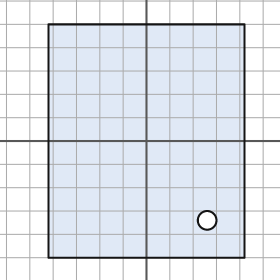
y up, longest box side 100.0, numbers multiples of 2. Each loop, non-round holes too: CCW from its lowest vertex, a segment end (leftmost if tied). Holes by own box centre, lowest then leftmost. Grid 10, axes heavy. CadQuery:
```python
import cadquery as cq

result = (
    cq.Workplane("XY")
    .moveTo(-42.0, -50.0)
    .lineTo(42.0, -50.0)
    .lineTo(42.0, 50.0)
    .lineTo(-42.0, 50.0)
    .close()
    .moveTo(26.0, -34.0)
    .circle(4.0)
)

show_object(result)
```